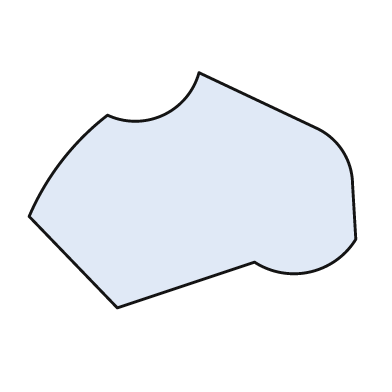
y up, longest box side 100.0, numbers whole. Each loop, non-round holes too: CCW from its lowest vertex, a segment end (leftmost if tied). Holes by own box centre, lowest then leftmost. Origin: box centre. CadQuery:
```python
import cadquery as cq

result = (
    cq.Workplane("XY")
    .moveTo(-23.0, -36.0)
    .lineTo(19.0, -22.0)
    .threePointArc((36.0, -25.0), (50.0, -15.0))
    .lineTo(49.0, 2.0)
    .threePointArc((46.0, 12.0), (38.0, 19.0))
    .lineTo(2.0, 36.0)
    .threePointArc((-9.0, 23.0), (-26.0, 23.0))
    .threePointArc((-40.0, 9.0), (-50.0, -8.0))
    .close()
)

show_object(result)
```